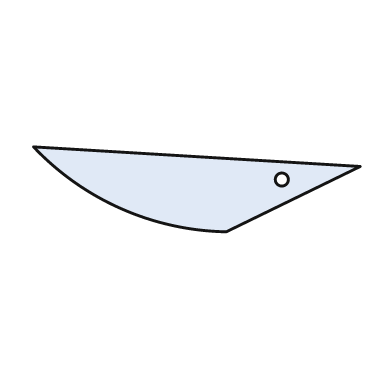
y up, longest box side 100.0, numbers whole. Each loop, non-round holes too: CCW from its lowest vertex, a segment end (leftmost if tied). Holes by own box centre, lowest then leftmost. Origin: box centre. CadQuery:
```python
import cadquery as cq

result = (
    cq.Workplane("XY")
    .moveTo(9.0, -13.0)
    .lineTo(50.0, 7.0)
    .lineTo(-50.0, 13.0)
    .threePointArc((-23.0, -6.0), (9.0, -13.0))
    .close()
    .moveTo(26.0, 3.0)
    .circle(2.0)
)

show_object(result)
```